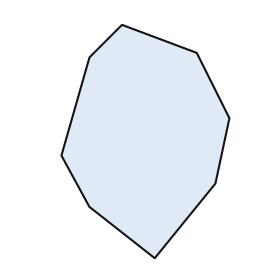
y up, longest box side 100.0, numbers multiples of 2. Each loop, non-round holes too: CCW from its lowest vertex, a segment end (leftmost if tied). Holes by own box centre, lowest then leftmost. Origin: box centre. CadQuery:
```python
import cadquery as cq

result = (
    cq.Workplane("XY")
    .moveTo(4.0, -50.0)
    .lineTo(30.0, -18.0)
    .lineTo(36.0, 10.0)
    .lineTo(22.0, 38.0)
    .lineTo(-10.0, 50.0)
    .lineTo(-24.0, 36.0)
    .lineTo(-36.0, -6.0)
    .lineTo(-24.0, -28.0)
    .close()
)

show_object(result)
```